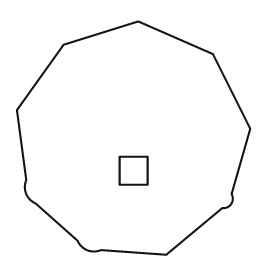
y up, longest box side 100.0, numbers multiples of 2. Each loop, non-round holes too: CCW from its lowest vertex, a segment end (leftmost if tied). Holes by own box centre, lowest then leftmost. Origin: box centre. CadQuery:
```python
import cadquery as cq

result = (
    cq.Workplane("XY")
    .moveTo(14.0, -50.0)
    .lineTo(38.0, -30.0)
    .threePointArc((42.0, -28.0), (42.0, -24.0))
    .lineTo(50.0, 4.0)
    .lineTo(34.0, 36.0)
    .lineTo(2.0, 50.0)
    .lineTo(-30.0, 40.0)
    .lineTo(-50.0, 12.0)
    .lineTo(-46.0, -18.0)
    .threePointArc((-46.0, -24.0), (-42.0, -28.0))
    .lineTo(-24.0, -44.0)
    .threePointArc((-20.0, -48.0), (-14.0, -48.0))
    .close()
    .moveTo(-6.0, -20.0)
    .lineTo(6.0, -20.0)
    .lineTo(6.0, -8.0)
    .lineTo(-6.0, -8.0)
    .close()
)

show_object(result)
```